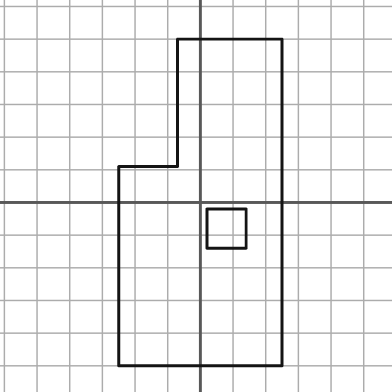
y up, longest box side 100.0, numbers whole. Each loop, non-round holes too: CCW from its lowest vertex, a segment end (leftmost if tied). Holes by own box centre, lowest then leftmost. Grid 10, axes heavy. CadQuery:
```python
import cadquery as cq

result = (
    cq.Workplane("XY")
    .moveTo(-25.0, -50.0)
    .lineTo(25.0, -50.0)
    .lineTo(25.0, 50.0)
    .lineTo(-7.0, 50.0)
    .lineTo(-7.0, 11.0)
    .lineTo(-25.0, 11.0)
    .close()
    .moveTo(2.0, -14.0)
    .lineTo(14.0, -14.0)
    .lineTo(14.0, -2.0)
    .lineTo(2.0, -2.0)
    .close()
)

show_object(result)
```